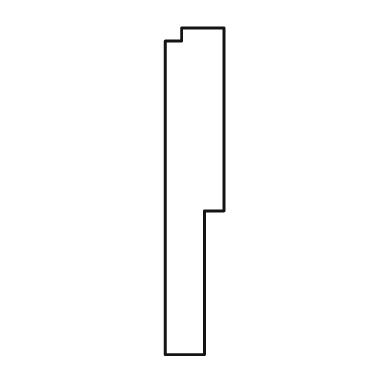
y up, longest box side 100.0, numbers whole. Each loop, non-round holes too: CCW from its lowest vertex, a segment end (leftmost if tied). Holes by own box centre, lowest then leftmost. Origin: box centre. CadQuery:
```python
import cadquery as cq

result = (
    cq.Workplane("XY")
    .moveTo(-9.0, -50.0)
    .lineTo(3.0, -50.0)
    .lineTo(3.0, -6.0)
    .lineTo(9.0, -6.0)
    .lineTo(9.0, 50.0)
    .lineTo(-4.0, 50.0)
    .lineTo(-4.0, 46.0)
    .lineTo(-9.0, 46.0)
    .close()
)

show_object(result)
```